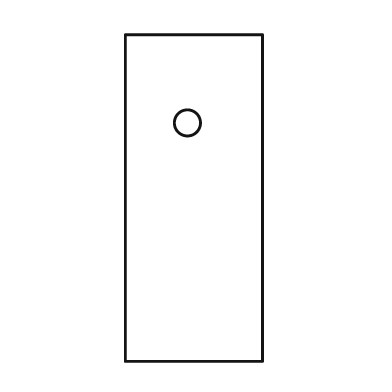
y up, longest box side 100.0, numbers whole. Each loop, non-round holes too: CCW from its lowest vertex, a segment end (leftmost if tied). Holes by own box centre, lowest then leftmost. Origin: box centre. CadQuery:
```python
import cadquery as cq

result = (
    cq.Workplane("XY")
    .moveTo(-21.0, -50.0)
    .lineTo(21.0, -50.0)
    .lineTo(21.0, 50.0)
    .lineTo(-21.0, 50.0)
    .close()
    .moveTo(-2.0, 23.0)
    .circle(4.0)
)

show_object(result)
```